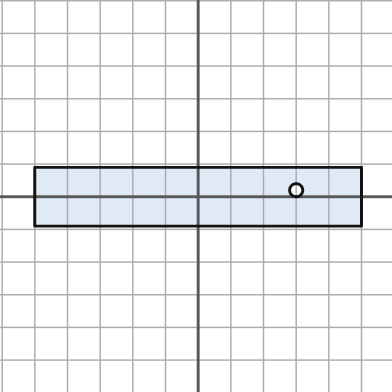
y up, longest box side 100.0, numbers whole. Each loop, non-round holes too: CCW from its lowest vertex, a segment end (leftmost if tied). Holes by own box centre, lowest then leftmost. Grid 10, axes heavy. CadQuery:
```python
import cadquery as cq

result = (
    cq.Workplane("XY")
    .moveTo(-50.0, -9.0)
    .lineTo(50.0, -9.0)
    .lineTo(50.0, 9.0)
    .lineTo(-50.0, 9.0)
    .close()
    .moveTo(30.0, 2.0)
    .circle(2.0)
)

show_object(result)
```